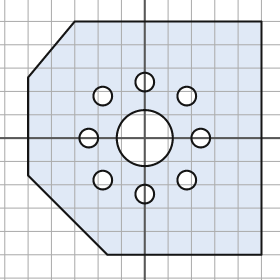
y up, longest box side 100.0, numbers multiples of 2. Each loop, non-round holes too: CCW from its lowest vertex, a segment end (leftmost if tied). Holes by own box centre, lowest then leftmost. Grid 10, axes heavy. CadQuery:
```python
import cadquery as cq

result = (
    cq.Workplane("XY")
    .moveTo(-16.0, -50.0)
    .lineTo(50.0, -50.0)
    .lineTo(50.0, 50.0)
    .lineTo(-30.0, 50.0)
    .lineTo(-50.0, 26.0)
    .lineTo(-50.0, -16.0)
    .close()
    .moveTo(0.0, -24.0)
    .circle(4.0)
    .moveTo(-18.0, -18.0)
    .circle(4.0)
    .moveTo(18.0, -18.0)
    .circle(4.0)
    .moveTo(-24.0, 0.0)
    .circle(4.0)
    .moveTo(0.0, 0.0)
    .circle(12.0)
    .moveTo(24.0, 0.0)
    .circle(4.0)
    .moveTo(-18.0, 18.0)
    .circle(4.0)
    .moveTo(18.0, 18.0)
    .circle(4.0)
    .moveTo(0.0, 24.0)
    .circle(4.0)
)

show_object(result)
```